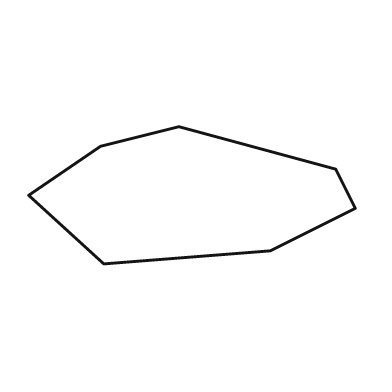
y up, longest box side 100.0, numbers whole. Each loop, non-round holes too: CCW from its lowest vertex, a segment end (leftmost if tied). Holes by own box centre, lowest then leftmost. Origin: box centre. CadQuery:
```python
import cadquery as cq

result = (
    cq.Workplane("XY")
    .moveTo(-27.0, -21.0)
    .lineTo(24.0, -17.0)
    .lineTo(50.0, -4.0)
    .lineTo(44.0, 8.0)
    .lineTo(-4.0, 21.0)
    .lineTo(-28.0, 15.0)
    .lineTo(-50.0, 0.0)
    .close()
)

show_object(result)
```